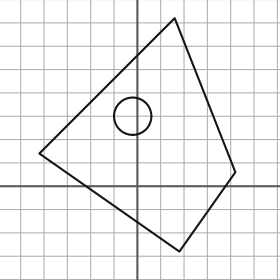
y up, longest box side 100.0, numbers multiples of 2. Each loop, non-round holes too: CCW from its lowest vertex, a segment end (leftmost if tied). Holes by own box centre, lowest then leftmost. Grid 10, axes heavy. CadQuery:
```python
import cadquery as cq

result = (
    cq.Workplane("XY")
    .moveTo(18.0, -28.0)
    .lineTo(42.0, 6.0)
    .lineTo(16.0, 72.0)
    .lineTo(-42.0, 14.0)
    .close()
    .moveTo(-2.0, 30.0)
    .circle(8.0)
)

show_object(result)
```